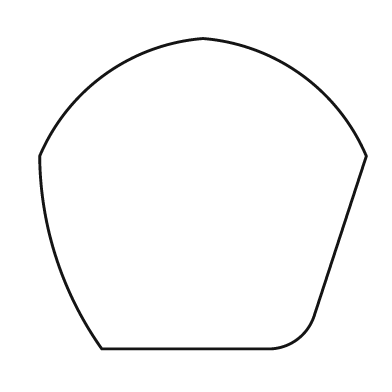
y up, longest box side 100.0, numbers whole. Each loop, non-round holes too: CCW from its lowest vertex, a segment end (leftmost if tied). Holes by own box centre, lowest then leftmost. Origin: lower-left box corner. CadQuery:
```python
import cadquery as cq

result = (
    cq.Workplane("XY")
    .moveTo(19.0, 0.0)
    .lineTo(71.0, 0.0)
    .threePointArc((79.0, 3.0), (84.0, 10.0))
    .lineTo(100.0, 59.0)
    .threePointArc((80.0, 84.0), (50.0, 95.0))
    .threePointArc((20.0, 84.0), (0.0, 59.0))
    .threePointArc((5.0, 28.0), (19.0, 0.0))
    .close()
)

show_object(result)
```